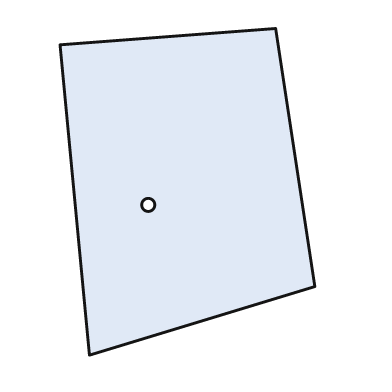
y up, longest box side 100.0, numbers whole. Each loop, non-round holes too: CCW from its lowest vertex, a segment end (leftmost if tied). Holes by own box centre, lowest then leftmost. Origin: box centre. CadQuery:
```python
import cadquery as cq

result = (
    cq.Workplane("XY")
    .moveTo(-30.0, -50.0)
    .lineTo(39.0, -29.0)
    .lineTo(27.0, 50.0)
    .lineTo(-39.0, 45.0)
    .close()
    .moveTo(-12.0, -4.0)
    .circle(2.0)
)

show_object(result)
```